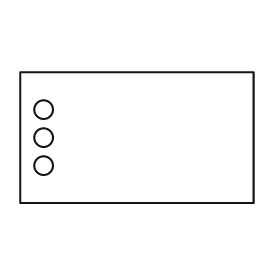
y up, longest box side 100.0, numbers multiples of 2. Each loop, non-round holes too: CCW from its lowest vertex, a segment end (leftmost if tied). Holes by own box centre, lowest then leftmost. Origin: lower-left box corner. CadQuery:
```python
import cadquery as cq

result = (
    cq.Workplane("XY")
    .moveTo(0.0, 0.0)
    .lineTo(100.0, 0.0)
    .lineTo(100.0, 56.0)
    .lineTo(0.0, 56.0)
    .close()
    .moveTo(10.0, 16.0)
    .circle(4.0)
    .moveTo(10.0, 28.0)
    .circle(4.0)
    .moveTo(10.0, 40.0)
    .circle(4.0)
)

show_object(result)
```